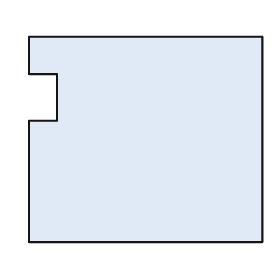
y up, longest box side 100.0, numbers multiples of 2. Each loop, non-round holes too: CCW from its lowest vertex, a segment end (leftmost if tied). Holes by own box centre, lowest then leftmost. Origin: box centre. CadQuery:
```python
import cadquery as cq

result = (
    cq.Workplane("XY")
    .moveTo(-50.0, -44.0)
    .lineTo(50.0, -44.0)
    .lineTo(50.0, 44.0)
    .lineTo(-50.0, 44.0)
    .lineTo(-50.0, 28.0)
    .lineTo(-38.0, 28.0)
    .lineTo(-38.0, 8.0)
    .lineTo(-50.0, 8.0)
    .close()
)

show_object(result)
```